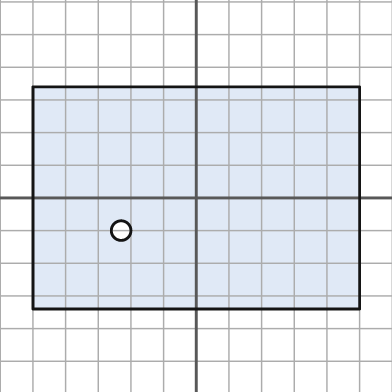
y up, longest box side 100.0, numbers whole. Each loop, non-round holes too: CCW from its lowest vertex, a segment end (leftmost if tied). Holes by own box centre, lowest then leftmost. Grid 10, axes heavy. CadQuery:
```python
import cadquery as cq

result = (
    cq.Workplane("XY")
    .moveTo(-50.0, -34.0)
    .lineTo(50.0, -34.0)
    .lineTo(50.0, 34.0)
    .lineTo(-50.0, 34.0)
    .close()
    .moveTo(-23.0, -10.0)
    .circle(3.0)
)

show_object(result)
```